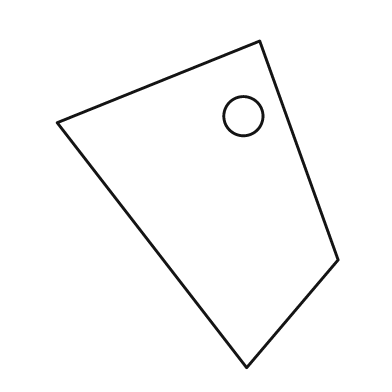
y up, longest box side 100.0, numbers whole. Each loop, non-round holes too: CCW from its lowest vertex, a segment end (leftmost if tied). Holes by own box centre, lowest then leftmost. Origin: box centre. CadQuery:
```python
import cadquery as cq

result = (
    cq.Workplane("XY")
    .moveTo(15.0, -50.0)
    .lineTo(43.0, -17.0)
    .lineTo(19.0, 50.0)
    .lineTo(-43.0, 25.0)
    .close()
    .moveTo(14.0, 27.0)
    .circle(6.0)
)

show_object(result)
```